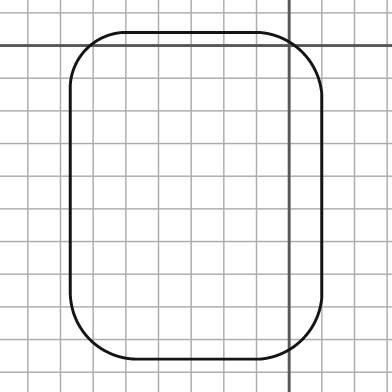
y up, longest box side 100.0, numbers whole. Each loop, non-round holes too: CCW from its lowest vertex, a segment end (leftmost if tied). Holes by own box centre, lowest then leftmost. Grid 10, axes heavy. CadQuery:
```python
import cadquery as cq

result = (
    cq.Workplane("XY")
    .moveTo(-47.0, -96.0)
    .lineTo(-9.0, -96.0)
    .threePointArc((4.0, -90.0), (10.0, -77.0))
    .lineTo(10.0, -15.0)
    .threePointArc((4.0, -2.0), (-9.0, 4.0))
    .lineTo(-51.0, 4.0)
    .threePointArc((-62.0, -1.0), (-67.0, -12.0))
    .lineTo(-67.0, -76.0)
    .threePointArc((-61.0, -90.0), (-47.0, -96.0))
    .close()
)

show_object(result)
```